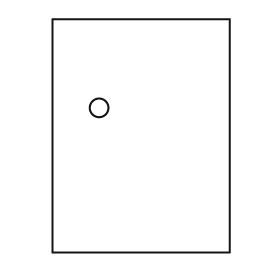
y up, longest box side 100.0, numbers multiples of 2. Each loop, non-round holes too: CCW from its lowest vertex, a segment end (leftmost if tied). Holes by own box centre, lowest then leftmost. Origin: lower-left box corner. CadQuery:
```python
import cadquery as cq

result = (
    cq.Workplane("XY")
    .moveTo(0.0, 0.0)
    .lineTo(76.0, 0.0)
    .lineTo(76.0, 100.0)
    .lineTo(0.0, 100.0)
    .close()
    .moveTo(20.0, 62.0)
    .circle(4.0)
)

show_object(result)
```